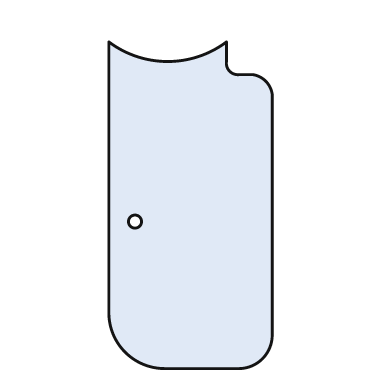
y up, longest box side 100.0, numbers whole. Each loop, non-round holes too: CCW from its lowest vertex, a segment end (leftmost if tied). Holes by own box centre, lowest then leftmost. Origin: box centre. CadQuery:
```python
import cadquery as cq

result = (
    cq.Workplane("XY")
    .moveTo(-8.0, -50.0)
    .lineTo(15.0, -50.0)
    .threePointArc((22.0, -47.0), (25.0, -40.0))
    .lineTo(25.0, 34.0)
    .threePointArc((23.0, 38.0), (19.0, 40.0))
    .lineTo(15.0, 40.0)
    .threePointArc((12.0, 41.0), (11.0, 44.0))
    .lineTo(11.0, 50.0)
    .threePointArc((-7.0, 44.0), (-25.0, 50.0))
    .lineTo(-25.0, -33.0)
    .threePointArc((-20.0, -45.0), (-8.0, -50.0))
    .close()
    .moveTo(-17.0, -5.0)
    .circle(2.0)
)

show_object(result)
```